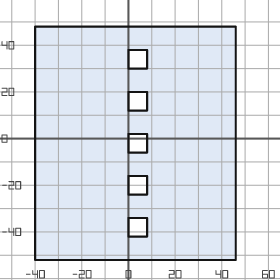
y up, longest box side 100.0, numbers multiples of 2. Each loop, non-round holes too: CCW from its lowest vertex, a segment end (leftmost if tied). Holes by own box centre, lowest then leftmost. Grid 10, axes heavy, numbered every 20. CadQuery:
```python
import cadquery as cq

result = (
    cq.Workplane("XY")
    .moveTo(-40.0, -52.0)
    .lineTo(46.0, -52.0)
    .lineTo(46.0, 48.0)
    .lineTo(-40.0, 48.0)
    .close()
    .moveTo(0.0, -42.0)
    .lineTo(8.0, -42.0)
    .lineTo(8.0, -34.0)
    .lineTo(0.0, -34.0)
    .close()
    .moveTo(0.0, -24.0)
    .lineTo(8.0, -24.0)
    .lineTo(8.0, -16.0)
    .lineTo(0.0, -16.0)
    .close()
    .moveTo(0.0, -6.0)
    .lineTo(8.0, -6.0)
    .lineTo(8.0, 2.0)
    .lineTo(0.0, 2.0)
    .close()
    .moveTo(0.0, 12.0)
    .lineTo(8.0, 12.0)
    .lineTo(8.0, 20.0)
    .lineTo(0.0, 20.0)
    .close()
    .moveTo(0.0, 30.0)
    .lineTo(8.0, 30.0)
    .lineTo(8.0, 38.0)
    .lineTo(0.0, 38.0)
    .close()
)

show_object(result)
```